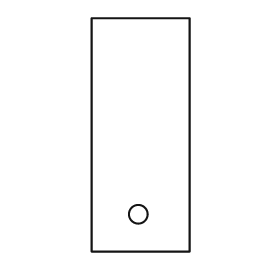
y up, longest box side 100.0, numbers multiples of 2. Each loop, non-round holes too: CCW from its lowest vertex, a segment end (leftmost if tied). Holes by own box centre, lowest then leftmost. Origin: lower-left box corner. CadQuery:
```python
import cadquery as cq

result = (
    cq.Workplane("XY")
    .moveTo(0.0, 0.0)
    .lineTo(42.0, 0.0)
    .lineTo(42.0, 100.0)
    .lineTo(0.0, 100.0)
    .close()
    .moveTo(20.0, 16.0)
    .circle(4.0)
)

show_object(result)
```